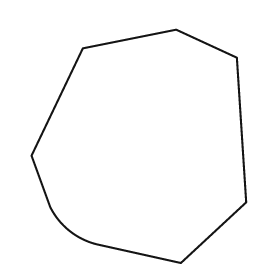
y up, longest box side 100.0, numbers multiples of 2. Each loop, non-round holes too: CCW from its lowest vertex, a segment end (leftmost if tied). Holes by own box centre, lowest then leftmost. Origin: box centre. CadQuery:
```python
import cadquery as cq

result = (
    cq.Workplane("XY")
    .moveTo(18.0, -50.0)
    .lineTo(46.0, -24.0)
    .lineTo(42.0, 38.0)
    .lineTo(16.0, 50.0)
    .lineTo(-24.0, 42.0)
    .lineTo(-46.0, -4.0)
    .lineTo(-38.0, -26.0)
    .threePointArc((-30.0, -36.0), (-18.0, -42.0))
    .close()
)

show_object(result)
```